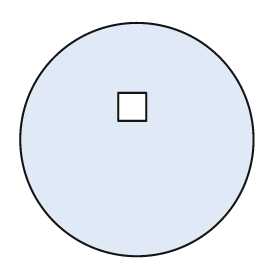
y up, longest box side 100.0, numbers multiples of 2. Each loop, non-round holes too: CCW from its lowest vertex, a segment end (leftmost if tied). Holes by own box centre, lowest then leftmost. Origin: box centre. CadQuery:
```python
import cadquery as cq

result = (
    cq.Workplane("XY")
    .moveTo(0.0, 0.0)
    .circle(50.0)
    .moveTo(-8.0, 8.0)
    .lineTo(4.0, 8.0)
    .lineTo(4.0, 20.0)
    .lineTo(-8.0, 20.0)
    .close()
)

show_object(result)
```